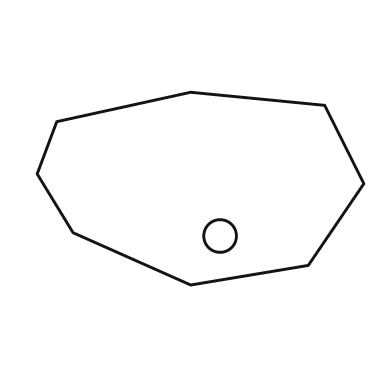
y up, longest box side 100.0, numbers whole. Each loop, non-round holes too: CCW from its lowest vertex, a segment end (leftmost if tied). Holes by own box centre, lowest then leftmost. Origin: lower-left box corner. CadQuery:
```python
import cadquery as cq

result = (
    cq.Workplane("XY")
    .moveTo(47.0, 0.0)
    .lineTo(83.0, 6.0)
    .lineTo(100.0, 31.0)
    .lineTo(88.0, 55.0)
    .lineTo(47.0, 59.0)
    .lineTo(6.0, 50.0)
    .lineTo(0.0, 34.0)
    .lineTo(11.0, 16.0)
    .close()
    .moveTo(56.0, 15.0)
    .circle(5.0)
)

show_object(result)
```